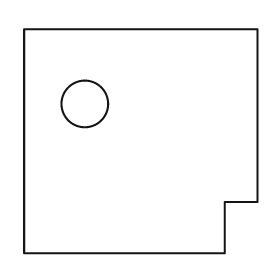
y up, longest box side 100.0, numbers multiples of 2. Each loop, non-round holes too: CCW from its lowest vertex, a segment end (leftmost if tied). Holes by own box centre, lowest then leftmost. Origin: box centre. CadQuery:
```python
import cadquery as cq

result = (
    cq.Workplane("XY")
    .moveTo(-50.0, -48.0)
    .lineTo(36.0, -48.0)
    .lineTo(36.0, -26.0)
    .lineTo(50.0, -26.0)
    .lineTo(50.0, 48.0)
    .lineTo(-50.0, 48.0)
    .close()
    .moveTo(-24.0, 16.0)
    .circle(10.0)
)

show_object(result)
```